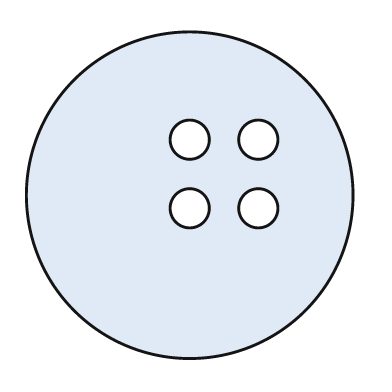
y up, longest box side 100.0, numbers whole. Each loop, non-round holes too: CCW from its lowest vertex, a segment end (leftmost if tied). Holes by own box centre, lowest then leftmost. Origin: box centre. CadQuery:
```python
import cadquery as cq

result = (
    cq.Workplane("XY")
    .moveTo(0.0, 0.0)
    .circle(50.0)
    .moveTo(0.0, -4.0)
    .circle(6.0)
    .moveTo(21.0, -4.0)
    .circle(6.0)
    .moveTo(0.0, 17.0)
    .circle(6.0)
    .moveTo(21.0, 17.0)
    .circle(6.0)
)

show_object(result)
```